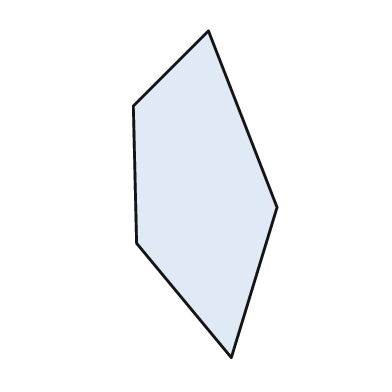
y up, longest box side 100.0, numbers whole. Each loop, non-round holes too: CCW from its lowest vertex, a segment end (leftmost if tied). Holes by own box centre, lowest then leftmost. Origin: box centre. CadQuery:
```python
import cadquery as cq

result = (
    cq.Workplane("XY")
    .moveTo(8.0, -50.0)
    .lineTo(22.0, -4.0)
    .lineTo(1.0, 50.0)
    .lineTo(-22.0, 27.0)
    .lineTo(-21.0, -15.0)
    .close()
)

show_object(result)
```